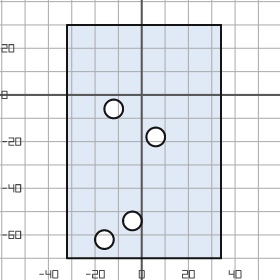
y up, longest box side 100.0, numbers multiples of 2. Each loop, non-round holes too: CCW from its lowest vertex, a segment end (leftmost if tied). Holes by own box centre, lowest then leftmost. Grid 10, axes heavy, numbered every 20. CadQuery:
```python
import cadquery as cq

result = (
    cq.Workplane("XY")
    .moveTo(-32.0, -70.0)
    .lineTo(34.0, -70.0)
    .lineTo(34.0, 30.0)
    .lineTo(-32.0, 30.0)
    .close()
    .moveTo(-16.0, -62.0)
    .circle(4.0)
    .moveTo(-4.0, -54.0)
    .circle(4.0)
    .moveTo(6.0, -18.0)
    .circle(4.0)
    .moveTo(-12.0, -6.0)
    .circle(4.0)
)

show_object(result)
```